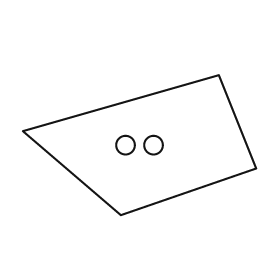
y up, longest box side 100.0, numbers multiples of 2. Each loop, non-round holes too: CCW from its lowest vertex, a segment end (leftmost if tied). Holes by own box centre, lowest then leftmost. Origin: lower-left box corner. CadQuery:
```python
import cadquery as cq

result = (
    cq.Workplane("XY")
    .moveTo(42.0, 0.0)
    .lineTo(100.0, 20.0)
    .lineTo(84.0, 60.0)
    .lineTo(0.0, 36.0)
    .close()
    .moveTo(44.0, 30.0)
    .circle(4.0)
    .moveTo(56.0, 30.0)
    .circle(4.0)
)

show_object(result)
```